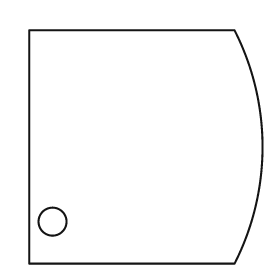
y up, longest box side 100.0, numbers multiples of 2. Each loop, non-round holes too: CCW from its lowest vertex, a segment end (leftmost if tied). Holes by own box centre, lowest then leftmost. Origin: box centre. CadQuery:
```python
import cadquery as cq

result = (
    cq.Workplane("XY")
    .moveTo(-50.0, -50.0)
    .lineTo(38.0, -50.0)
    .threePointArc((50.0, 0.0), (38.0, 50.0))
    .lineTo(-50.0, 50.0)
    .close()
    .moveTo(-40.0, -32.0)
    .circle(6.0)
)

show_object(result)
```